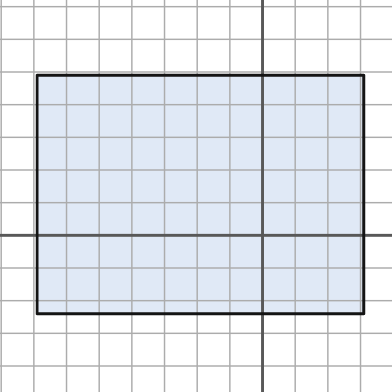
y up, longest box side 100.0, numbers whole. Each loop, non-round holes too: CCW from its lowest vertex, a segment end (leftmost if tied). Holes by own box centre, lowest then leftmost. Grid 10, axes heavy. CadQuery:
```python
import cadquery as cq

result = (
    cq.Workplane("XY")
    .moveTo(-69.0, -24.0)
    .lineTo(31.0, -24.0)
    .lineTo(31.0, 49.0)
    .lineTo(-69.0, 49.0)
    .close()
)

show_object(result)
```